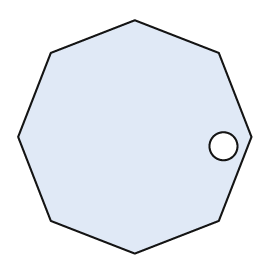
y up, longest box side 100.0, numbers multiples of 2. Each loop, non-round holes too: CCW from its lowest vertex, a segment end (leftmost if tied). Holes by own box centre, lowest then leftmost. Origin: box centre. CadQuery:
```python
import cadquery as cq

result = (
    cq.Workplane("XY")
    .moveTo(0.0, -50.0)
    .lineTo(36.0, -36.0)
    .lineTo(50.0, 0.0)
    .lineTo(36.0, 36.0)
    .lineTo(0.0, 50.0)
    .lineTo(-36.0, 36.0)
    .lineTo(-50.0, 0.0)
    .lineTo(-36.0, -36.0)
    .close()
    .moveTo(38.0, -4.0)
    .circle(6.0)
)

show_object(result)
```